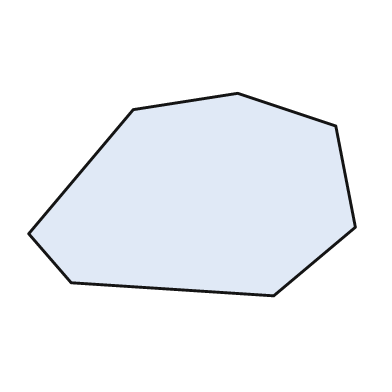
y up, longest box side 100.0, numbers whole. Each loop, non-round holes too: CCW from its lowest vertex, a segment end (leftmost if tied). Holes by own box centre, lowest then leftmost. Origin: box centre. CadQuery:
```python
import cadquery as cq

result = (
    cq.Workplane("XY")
    .moveTo(25.0, -31.0)
    .lineTo(50.0, -10.0)
    .lineTo(44.0, 21.0)
    .lineTo(14.0, 31.0)
    .lineTo(-18.0, 26.0)
    .lineTo(-50.0, -12.0)
    .lineTo(-37.0, -27.0)
    .close()
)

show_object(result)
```